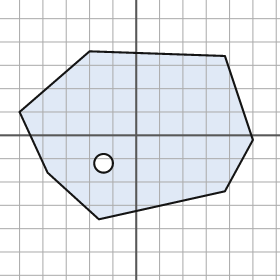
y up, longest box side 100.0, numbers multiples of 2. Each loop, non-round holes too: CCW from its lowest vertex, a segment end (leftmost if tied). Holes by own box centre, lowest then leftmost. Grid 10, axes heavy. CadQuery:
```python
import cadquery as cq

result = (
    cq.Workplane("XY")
    .moveTo(-16.0, -36.0)
    .lineTo(38.0, -24.0)
    .lineTo(50.0, -2.0)
    .lineTo(38.0, 34.0)
    .lineTo(-20.0, 36.0)
    .lineTo(-50.0, 10.0)
    .lineTo(-38.0, -16.0)
    .close()
    .moveTo(-14.0, -12.0)
    .circle(4.0)
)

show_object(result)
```